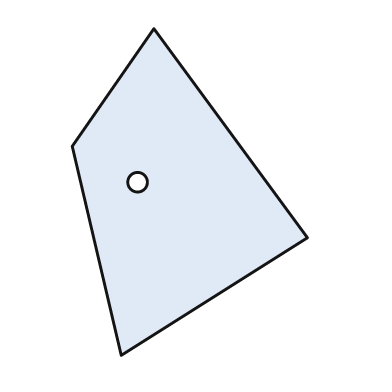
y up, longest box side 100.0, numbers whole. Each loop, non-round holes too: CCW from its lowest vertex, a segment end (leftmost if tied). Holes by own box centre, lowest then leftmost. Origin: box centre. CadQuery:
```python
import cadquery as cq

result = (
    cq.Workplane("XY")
    .moveTo(-21.0, -50.0)
    .lineTo(36.0, -14.0)
    .lineTo(-11.0, 50.0)
    .lineTo(-36.0, 14.0)
    .close()
    .moveTo(-16.0, 3.0)
    .circle(3.0)
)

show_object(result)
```